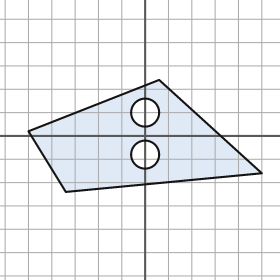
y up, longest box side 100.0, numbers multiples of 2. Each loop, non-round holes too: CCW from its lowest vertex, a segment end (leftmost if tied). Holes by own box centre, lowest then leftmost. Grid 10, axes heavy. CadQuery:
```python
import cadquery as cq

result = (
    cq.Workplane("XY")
    .moveTo(-34.0, -24.0)
    .lineTo(50.0, -16.0)
    .lineTo(6.0, 24.0)
    .lineTo(-50.0, 2.0)
    .close()
    .moveTo(0.0, -8.0)
    .circle(6.0)
    .moveTo(0.0, 10.0)
    .circle(6.0)
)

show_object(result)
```